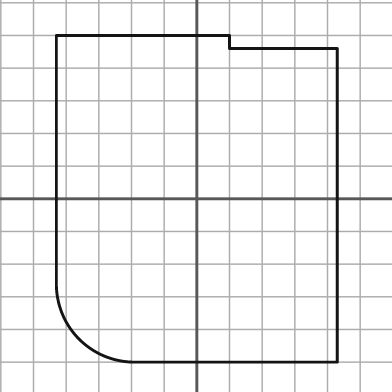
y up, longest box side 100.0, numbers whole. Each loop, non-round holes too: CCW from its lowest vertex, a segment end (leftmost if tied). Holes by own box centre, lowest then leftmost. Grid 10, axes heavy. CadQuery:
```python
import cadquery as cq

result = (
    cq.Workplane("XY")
    .moveTo(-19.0, -50.0)
    .lineTo(43.0, -50.0)
    .lineTo(43.0, 46.0)
    .lineTo(10.0, 46.0)
    .lineTo(10.0, 50.0)
    .lineTo(-43.0, 50.0)
    .lineTo(-43.0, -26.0)
    .threePointArc((-36.0, -43.0), (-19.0, -50.0))
    .close()
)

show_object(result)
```